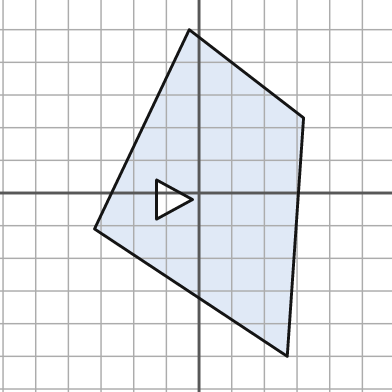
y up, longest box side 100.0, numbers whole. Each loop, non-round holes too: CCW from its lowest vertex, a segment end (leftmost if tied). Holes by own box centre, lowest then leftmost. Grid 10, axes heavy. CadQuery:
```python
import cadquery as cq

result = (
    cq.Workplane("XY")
    .moveTo(27.0, -50.0)
    .lineTo(32.0, 23.0)
    .lineTo(-3.0, 50.0)
    .lineTo(-32.0, -11.0)
    .close()
    .moveTo(-13.0, -8.0)
    .lineTo(-2.0, -2.0)
    .lineTo(-13.0, 4.0)
    .close()
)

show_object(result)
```